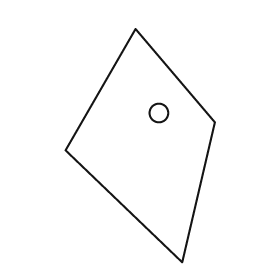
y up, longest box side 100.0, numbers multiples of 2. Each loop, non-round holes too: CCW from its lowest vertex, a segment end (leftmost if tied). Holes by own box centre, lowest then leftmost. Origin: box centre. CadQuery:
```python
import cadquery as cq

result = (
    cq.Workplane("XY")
    .moveTo(18.0, -50.0)
    .lineTo(32.0, 10.0)
    .lineTo(-2.0, 50.0)
    .lineTo(-32.0, -2.0)
    .close()
    .moveTo(8.0, 14.0)
    .circle(4.0)
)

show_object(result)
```